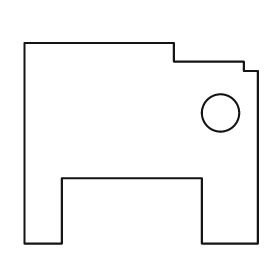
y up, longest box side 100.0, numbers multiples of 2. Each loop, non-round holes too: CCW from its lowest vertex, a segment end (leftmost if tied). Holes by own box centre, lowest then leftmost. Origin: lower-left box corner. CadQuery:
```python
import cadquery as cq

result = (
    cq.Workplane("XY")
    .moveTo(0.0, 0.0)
    .lineTo(16.0, 0.0)
    .lineTo(16.0, 28.0)
    .lineTo(76.0, 28.0)
    .lineTo(76.0, 0.0)
    .lineTo(100.0, 0.0)
    .lineTo(100.0, 74.0)
    .lineTo(94.0, 74.0)
    .lineTo(94.0, 78.0)
    .lineTo(64.0, 78.0)
    .lineTo(64.0, 86.0)
    .lineTo(0.0, 86.0)
    .close()
    .moveTo(84.0, 56.0)
    .circle(8.0)
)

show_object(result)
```